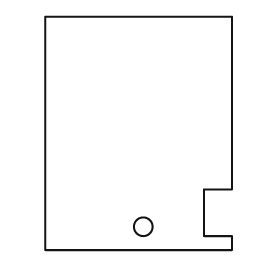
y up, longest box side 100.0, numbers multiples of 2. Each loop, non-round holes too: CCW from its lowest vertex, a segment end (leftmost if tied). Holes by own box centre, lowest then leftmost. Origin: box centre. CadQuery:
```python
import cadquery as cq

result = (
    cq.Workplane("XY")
    .moveTo(-40.0, -50.0)
    .lineTo(40.0, -50.0)
    .lineTo(40.0, -44.0)
    .lineTo(28.0, -44.0)
    .lineTo(28.0, -24.0)
    .lineTo(40.0, -24.0)
    .lineTo(40.0, 50.0)
    .lineTo(-40.0, 50.0)
    .close()
    .moveTo(2.0, -40.0)
    .circle(4.0)
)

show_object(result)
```